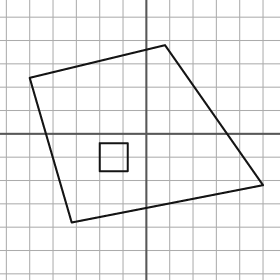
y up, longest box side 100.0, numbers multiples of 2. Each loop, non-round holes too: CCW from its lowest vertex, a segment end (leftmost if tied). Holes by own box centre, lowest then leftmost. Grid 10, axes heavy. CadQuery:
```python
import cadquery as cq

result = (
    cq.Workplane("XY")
    .moveTo(-32.0, -38.0)
    .lineTo(50.0, -22.0)
    .lineTo(8.0, 38.0)
    .lineTo(-50.0, 24.0)
    .close()
    .moveTo(-20.0, -16.0)
    .lineTo(-8.0, -16.0)
    .lineTo(-8.0, -4.0)
    .lineTo(-20.0, -4.0)
    .close()
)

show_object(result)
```